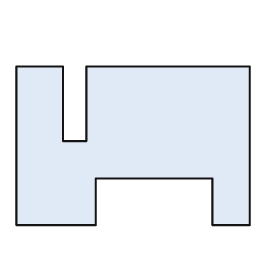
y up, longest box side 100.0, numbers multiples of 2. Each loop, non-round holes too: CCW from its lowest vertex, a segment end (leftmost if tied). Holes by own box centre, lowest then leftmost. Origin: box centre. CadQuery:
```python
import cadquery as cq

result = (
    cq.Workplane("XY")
    .moveTo(-50.0, -34.0)
    .lineTo(-16.0, -34.0)
    .lineTo(-16.0, -14.0)
    .lineTo(34.0, -14.0)
    .lineTo(34.0, -34.0)
    .lineTo(50.0, -34.0)
    .lineTo(50.0, 34.0)
    .lineTo(-20.0, 34.0)
    .lineTo(-20.0, 2.0)
    .lineTo(-30.0, 2.0)
    .lineTo(-30.0, 34.0)
    .lineTo(-50.0, 34.0)
    .close()
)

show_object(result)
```